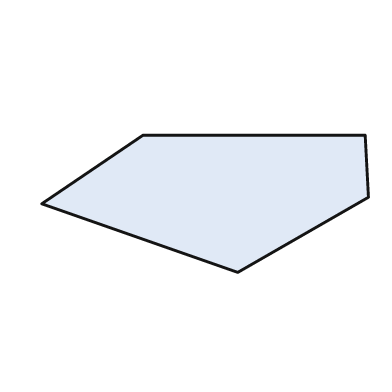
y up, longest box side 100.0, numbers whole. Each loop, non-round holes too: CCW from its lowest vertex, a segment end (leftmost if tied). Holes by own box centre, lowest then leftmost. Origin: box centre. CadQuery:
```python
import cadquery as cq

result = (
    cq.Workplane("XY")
    .moveTo(10.0, -21.0)
    .lineTo(50.0, 2.0)
    .lineTo(49.0, 21.0)
    .lineTo(-19.0, 21.0)
    .lineTo(-50.0, 0.0)
    .close()
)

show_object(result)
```